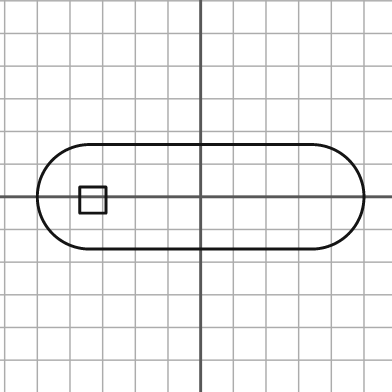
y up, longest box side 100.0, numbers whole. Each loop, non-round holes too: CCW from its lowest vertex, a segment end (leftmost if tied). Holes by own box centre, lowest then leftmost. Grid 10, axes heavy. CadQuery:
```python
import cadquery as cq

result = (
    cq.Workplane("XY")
    .moveTo(-34.0, -16.0)
    .lineTo(34.0, -16.0)
    .threePointArc((50.0, 0.0), (34.0, 16.0))
    .lineTo(-34.0, 16.0)
    .threePointArc((-50.0, 0.0), (-34.0, -16.0))
    .close()
    .moveTo(-37.0, -5.0)
    .lineTo(-29.0, -5.0)
    .lineTo(-29.0, 3.0)
    .lineTo(-37.0, 3.0)
    .close()
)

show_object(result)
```